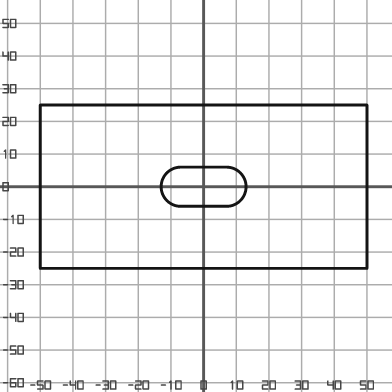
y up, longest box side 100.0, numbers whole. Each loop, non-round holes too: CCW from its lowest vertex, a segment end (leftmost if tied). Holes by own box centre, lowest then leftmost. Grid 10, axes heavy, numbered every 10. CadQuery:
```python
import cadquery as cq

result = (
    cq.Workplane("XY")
    .moveTo(-50.0, -25.0)
    .lineTo(50.0, -25.0)
    .lineTo(50.0, 25.0)
    .lineTo(-50.0, 25.0)
    .close()
    .moveTo(-7.0, -6.0)
    .lineTo(7.0, -6.0)
    .threePointArc((13.0, 0.0), (7.0, 6.0))
    .lineTo(-7.0, 6.0)
    .threePointArc((-13.0, 0.0), (-7.0, -6.0))
    .close()
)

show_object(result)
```